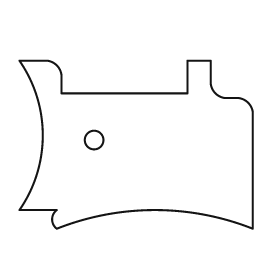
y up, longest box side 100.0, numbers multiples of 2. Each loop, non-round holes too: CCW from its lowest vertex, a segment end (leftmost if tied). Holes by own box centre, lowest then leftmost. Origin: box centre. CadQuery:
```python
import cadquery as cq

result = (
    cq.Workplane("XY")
    .moveTo(-34.0, -36.0)
    .threePointArc((8.0, -28.0), (50.0, -36.0))
    .lineTo(50.0, 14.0)
    .threePointArc((48.0, 18.0), (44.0, 20.0))
    .lineTo(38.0, 20.0)
    .threePointArc((34.0, 22.0), (32.0, 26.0))
    .lineTo(32.0, 36.0)
    .lineTo(22.0, 36.0)
    .lineTo(22.0, 22.0)
    .lineTo(-32.0, 22.0)
    .lineTo(-32.0, 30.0)
    .threePointArc((-34.0, 34.0), (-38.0, 36.0))
    .lineTo(-50.0, 36.0)
    .threePointArc((-40.0, 4.0), (-50.0, -28.0))
    .lineTo(-34.0, -28.0)
    .threePointArc((-36.0, -32.0), (-34.0, -36.0))
    .close()
    .moveTo(-18.0, 2.0)
    .circle(4.0)
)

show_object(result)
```